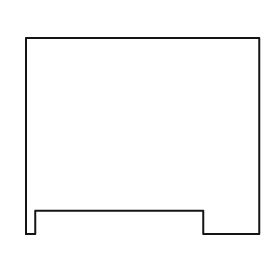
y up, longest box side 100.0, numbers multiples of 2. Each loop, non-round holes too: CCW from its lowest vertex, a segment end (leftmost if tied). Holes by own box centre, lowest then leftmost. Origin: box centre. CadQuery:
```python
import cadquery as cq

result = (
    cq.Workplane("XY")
    .moveTo(-50.0, -42.0)
    .lineTo(-46.0, -42.0)
    .lineTo(-46.0, -32.0)
    .lineTo(26.0, -32.0)
    .lineTo(26.0, -42.0)
    .lineTo(50.0, -42.0)
    .lineTo(50.0, 42.0)
    .lineTo(-50.0, 42.0)
    .close()
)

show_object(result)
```